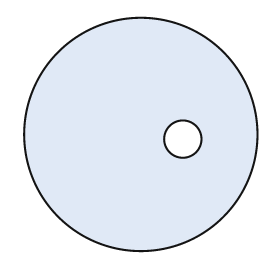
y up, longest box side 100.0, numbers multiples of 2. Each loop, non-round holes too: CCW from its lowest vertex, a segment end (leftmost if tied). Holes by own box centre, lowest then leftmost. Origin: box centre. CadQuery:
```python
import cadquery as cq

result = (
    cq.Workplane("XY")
    .moveTo(0.0, 0.0)
    .circle(50.0)
    .moveTo(18.0, -2.0)
    .circle(8.0)
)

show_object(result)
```